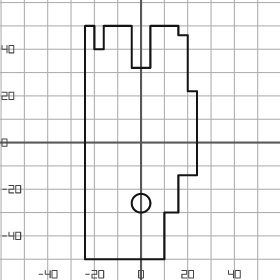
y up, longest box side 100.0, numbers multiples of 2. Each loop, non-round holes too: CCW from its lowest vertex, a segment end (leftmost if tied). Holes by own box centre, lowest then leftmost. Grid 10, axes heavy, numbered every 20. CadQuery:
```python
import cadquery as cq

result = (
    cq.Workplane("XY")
    .moveTo(-24.0, -50.0)
    .lineTo(10.0, -50.0)
    .lineTo(10.0, -30.0)
    .lineTo(16.0, -30.0)
    .lineTo(16.0, -14.0)
    .lineTo(24.0, -14.0)
    .lineTo(24.0, 22.0)
    .lineTo(20.0, 22.0)
    .lineTo(20.0, 46.0)
    .lineTo(16.0, 46.0)
    .lineTo(16.0, 50.0)
    .lineTo(4.0, 50.0)
    .lineTo(4.0, 32.0)
    .lineTo(-4.0, 32.0)
    .lineTo(-4.0, 50.0)
    .lineTo(-16.0, 50.0)
    .lineTo(-16.0, 40.0)
    .lineTo(-20.0, 40.0)
    .lineTo(-20.0, 50.0)
    .lineTo(-24.0, 50.0)
    .close()
    .moveTo(0.0, -26.0)
    .circle(4.0)
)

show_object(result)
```